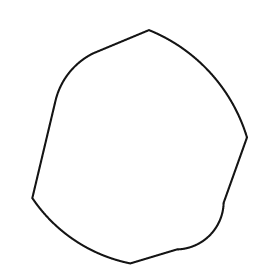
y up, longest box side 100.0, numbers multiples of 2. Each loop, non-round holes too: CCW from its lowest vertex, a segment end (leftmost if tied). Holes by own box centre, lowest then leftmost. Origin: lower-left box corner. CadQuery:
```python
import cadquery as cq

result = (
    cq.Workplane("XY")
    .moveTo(42.0, 0.0)
    .lineTo(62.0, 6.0)
    .threePointArc((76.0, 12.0), (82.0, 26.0))
    .lineTo(92.0, 54.0)
    .threePointArc((76.0, 82.0), (50.0, 100.0))
    .lineTo(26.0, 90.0)
    .threePointArc((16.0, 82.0), (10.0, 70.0))
    .lineTo(0.0, 28.0)
    .threePointArc((18.0, 10.0), (42.0, 0.0))
    .close()
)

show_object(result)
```